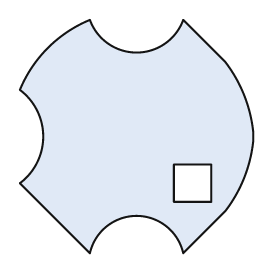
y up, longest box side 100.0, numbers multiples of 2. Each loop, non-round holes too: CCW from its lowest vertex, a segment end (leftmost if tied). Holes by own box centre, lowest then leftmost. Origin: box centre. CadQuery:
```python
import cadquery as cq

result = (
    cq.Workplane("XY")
    .moveTo(-20.0, -50.0)
    .threePointArc((0.0, -34.0), (20.0, -50.0))
    .lineTo(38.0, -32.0)
    .threePointArc((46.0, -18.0), (50.0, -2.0))
    .lineTo(50.0, 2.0)
    .threePointArc((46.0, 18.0), (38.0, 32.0))
    .lineTo(20.0, 50.0)
    .threePointArc((0.0, 36.0), (-20.0, 50.0))
    .threePointArc((-38.0, 38.0), (-50.0, 20.0))
    .threePointArc((-40.0, 0.0), (-50.0, -20.0))
    .close()
    .moveTo(16.0, -28.0)
    .lineTo(32.0, -28.0)
    .lineTo(32.0, -12.0)
    .lineTo(16.0, -12.0)
    .close()
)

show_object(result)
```